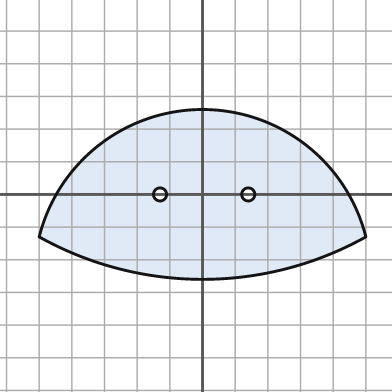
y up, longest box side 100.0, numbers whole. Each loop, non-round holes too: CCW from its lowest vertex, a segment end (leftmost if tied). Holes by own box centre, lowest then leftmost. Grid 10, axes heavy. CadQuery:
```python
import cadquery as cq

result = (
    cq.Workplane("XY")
    .moveTo(-50.0, -13.0)
    .threePointArc((0.0, -26.0), (50.0, -13.0))
    .threePointArc((0.0, 26.0), (-50.0, -13.0))
    .close()
    .moveTo(-13.0, 0.0)
    .circle(2.0)
    .moveTo(14.0, 0.0)
    .circle(2.0)
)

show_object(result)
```